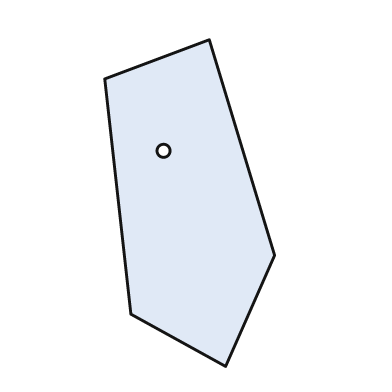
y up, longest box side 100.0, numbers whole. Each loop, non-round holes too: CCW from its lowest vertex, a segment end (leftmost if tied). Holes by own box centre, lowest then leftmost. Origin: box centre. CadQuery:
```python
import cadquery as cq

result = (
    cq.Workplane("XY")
    .moveTo(11.0, -50.0)
    .lineTo(26.0, -16.0)
    .lineTo(6.0, 50.0)
    .lineTo(-26.0, 38.0)
    .lineTo(-18.0, -34.0)
    .close()
    .moveTo(-8.0, 16.0)
    .circle(2.0)
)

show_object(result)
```